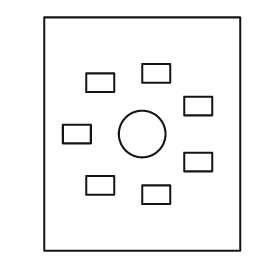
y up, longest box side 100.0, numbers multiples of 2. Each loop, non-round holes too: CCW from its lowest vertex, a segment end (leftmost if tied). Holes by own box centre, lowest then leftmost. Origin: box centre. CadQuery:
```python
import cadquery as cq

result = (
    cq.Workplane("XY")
    .moveTo(-42.0, -50.0)
    .lineTo(42.0, -50.0)
    .lineTo(42.0, 50.0)
    .lineTo(-42.0, 50.0)
    .close()
    .moveTo(0.0, -30.0)
    .lineTo(12.0, -30.0)
    .lineTo(12.0, -22.0)
    .lineTo(0.0, -22.0)
    .close()
    .moveTo(-24.0, -26.0)
    .lineTo(-12.0, -26.0)
    .lineTo(-12.0, -18.0)
    .lineTo(-24.0, -18.0)
    .close()
    .moveTo(18.0, -16.0)
    .lineTo(30.0, -16.0)
    .lineTo(30.0, -8.0)
    .lineTo(18.0, -8.0)
    .close()
    .moveTo(-34.0, -4.0)
    .lineTo(-22.0, -4.0)
    .lineTo(-22.0, 4.0)
    .lineTo(-34.0, 4.0)
    .close()
    .moveTo(0.0, 0.0)
    .circle(10.0)
    .moveTo(18.0, 8.0)
    .lineTo(30.0, 8.0)
    .lineTo(30.0, 16.0)
    .lineTo(18.0, 16.0)
    .close()
    .moveTo(-24.0, 18.0)
    .lineTo(-12.0, 18.0)
    .lineTo(-12.0, 26.0)
    .lineTo(-24.0, 26.0)
    .close()
    .moveTo(0.0, 22.0)
    .lineTo(12.0, 22.0)
    .lineTo(12.0, 30.0)
    .lineTo(0.0, 30.0)
    .close()
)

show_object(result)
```